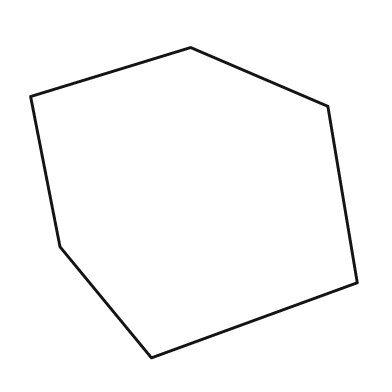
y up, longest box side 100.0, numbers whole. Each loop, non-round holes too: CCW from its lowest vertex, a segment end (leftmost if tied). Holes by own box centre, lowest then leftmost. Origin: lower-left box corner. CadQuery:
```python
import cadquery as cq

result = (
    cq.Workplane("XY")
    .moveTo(37.0, 0.0)
    .lineTo(100.0, 23.0)
    .lineTo(91.0, 77.0)
    .lineTo(49.0, 95.0)
    .lineTo(0.0, 80.0)
    .lineTo(9.0, 34.0)
    .close()
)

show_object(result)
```